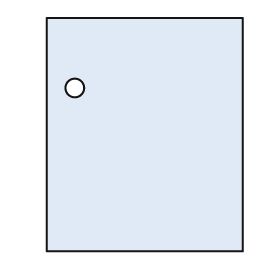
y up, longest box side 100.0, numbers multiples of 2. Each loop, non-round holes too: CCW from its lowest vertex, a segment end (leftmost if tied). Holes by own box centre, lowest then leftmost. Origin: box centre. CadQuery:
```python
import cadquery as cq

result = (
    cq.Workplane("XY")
    .moveTo(-42.0, -50.0)
    .lineTo(42.0, -50.0)
    .lineTo(42.0, 50.0)
    .lineTo(-42.0, 50.0)
    .close()
    .moveTo(-30.0, 20.0)
    .circle(4.0)
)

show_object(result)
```